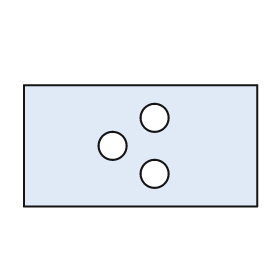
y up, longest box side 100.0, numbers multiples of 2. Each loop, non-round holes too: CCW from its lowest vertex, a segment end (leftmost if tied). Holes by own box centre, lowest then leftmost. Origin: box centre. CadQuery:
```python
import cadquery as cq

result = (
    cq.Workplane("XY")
    .moveTo(-50.0, -26.0)
    .lineTo(50.0, -26.0)
    .lineTo(50.0, 26.0)
    .lineTo(-50.0, 26.0)
    .close()
    .moveTo(6.0, -12.0)
    .circle(6.0)
    .moveTo(-12.0, 0.0)
    .circle(6.0)
    .moveTo(6.0, 12.0)
    .circle(6.0)
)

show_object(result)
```